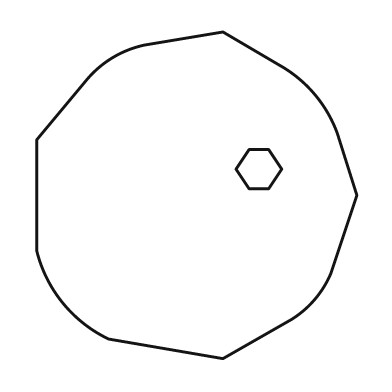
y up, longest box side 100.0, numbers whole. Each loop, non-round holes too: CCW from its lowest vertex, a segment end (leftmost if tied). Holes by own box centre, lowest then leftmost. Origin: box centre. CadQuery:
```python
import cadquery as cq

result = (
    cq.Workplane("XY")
    .moveTo(8.0, -50.0)
    .lineTo(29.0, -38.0)
    .threePointArc((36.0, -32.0), (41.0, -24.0))
    .lineTo(49.0, 0.0)
    .lineTo(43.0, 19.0)
    .threePointArc((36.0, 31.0), (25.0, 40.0))
    .lineTo(8.0, 50.0)
    .lineTo(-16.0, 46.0)
    .threePointArc((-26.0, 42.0), (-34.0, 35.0))
    .lineTo(-49.0, 17.0)
    .lineTo(-49.0, -17.0)
    .threePointArc((-41.0, -33.0), (-27.0, -44.0))
    .close()
    .moveTo(16.0, 2.0)
    .lineTo(22.0, 2.0)
    .lineTo(26.0, 8.0)
    .lineTo(22.0, 14.0)
    .lineTo(16.0, 14.0)
    .lineTo(12.0, 8.0)
    .close()
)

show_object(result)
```